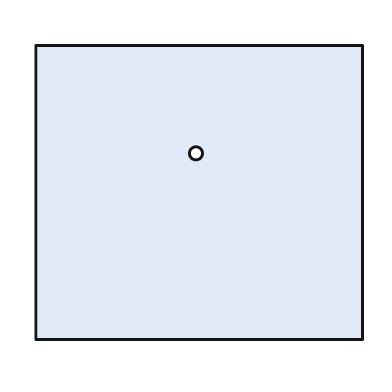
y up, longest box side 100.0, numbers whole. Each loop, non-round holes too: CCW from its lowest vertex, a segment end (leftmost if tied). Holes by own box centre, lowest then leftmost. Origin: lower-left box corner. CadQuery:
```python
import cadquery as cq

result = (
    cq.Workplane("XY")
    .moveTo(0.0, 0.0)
    .lineTo(100.0, 0.0)
    .lineTo(100.0, 90.0)
    .lineTo(0.0, 90.0)
    .close()
    .moveTo(49.0, 57.0)
    .circle(2.0)
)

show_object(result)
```